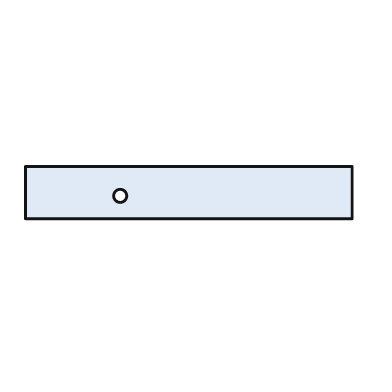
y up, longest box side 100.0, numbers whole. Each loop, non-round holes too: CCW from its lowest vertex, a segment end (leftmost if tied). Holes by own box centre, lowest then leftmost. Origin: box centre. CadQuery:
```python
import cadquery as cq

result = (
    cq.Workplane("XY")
    .moveTo(-50.0, -8.0)
    .lineTo(50.0, -8.0)
    .lineTo(50.0, 8.0)
    .lineTo(-50.0, 8.0)
    .close()
    .moveTo(-21.0, -1.0)
    .circle(2.0)
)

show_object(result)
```